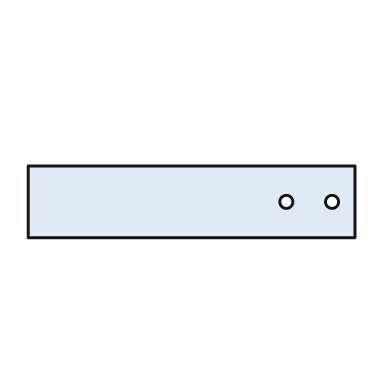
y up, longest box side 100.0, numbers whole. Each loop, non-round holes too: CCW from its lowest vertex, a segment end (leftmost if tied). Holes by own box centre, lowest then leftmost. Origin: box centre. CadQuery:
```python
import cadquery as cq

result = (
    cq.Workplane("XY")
    .moveTo(-50.0, -11.0)
    .lineTo(50.0, -11.0)
    .lineTo(50.0, 11.0)
    .lineTo(-50.0, 11.0)
    .close()
    .moveTo(29.0, 0.0)
    .circle(2.0)
    .moveTo(43.0, 0.0)
    .circle(2.0)
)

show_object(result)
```